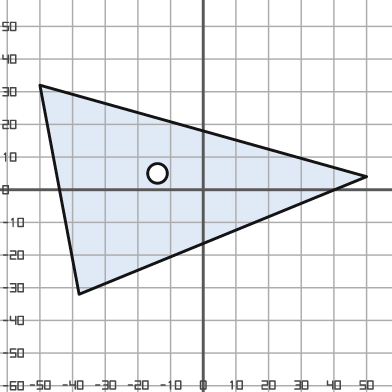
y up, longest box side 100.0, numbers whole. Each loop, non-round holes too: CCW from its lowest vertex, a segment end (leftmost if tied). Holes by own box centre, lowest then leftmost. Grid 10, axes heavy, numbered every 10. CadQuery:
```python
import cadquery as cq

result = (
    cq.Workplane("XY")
    .moveTo(-38.0, -32.0)
    .lineTo(50.0, 4.0)
    .lineTo(-50.0, 32.0)
    .close()
    .moveTo(-14.0, 5.0)
    .circle(3.0)
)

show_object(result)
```